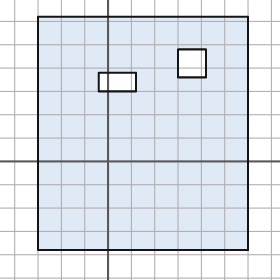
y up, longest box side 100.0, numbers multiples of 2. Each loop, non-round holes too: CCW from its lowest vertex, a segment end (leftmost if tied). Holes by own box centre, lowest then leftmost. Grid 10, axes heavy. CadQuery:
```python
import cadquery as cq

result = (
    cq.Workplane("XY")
    .moveTo(-30.0, -38.0)
    .lineTo(60.0, -38.0)
    .lineTo(60.0, 62.0)
    .lineTo(-30.0, 62.0)
    .close()
    .moveTo(-4.0, 30.0)
    .lineTo(12.0, 30.0)
    .lineTo(12.0, 38.0)
    .lineTo(-4.0, 38.0)
    .close()
    .moveTo(30.0, 36.0)
    .lineTo(42.0, 36.0)
    .lineTo(42.0, 48.0)
    .lineTo(30.0, 48.0)
    .close()
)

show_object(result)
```